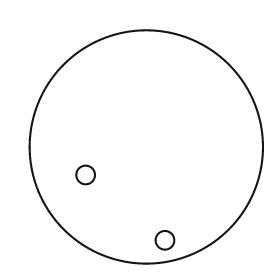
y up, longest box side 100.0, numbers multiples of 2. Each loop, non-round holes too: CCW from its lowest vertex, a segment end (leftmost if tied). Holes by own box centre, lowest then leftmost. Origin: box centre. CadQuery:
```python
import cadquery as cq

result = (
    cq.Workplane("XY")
    .moveTo(0.0, 0.0)
    .circle(50.0)
    .moveTo(8.0, -40.0)
    .circle(4.0)
    .moveTo(-26.0, -12.0)
    .circle(4.0)
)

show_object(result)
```